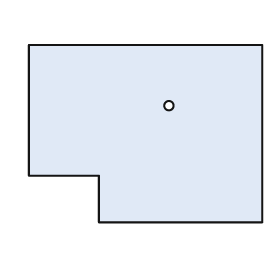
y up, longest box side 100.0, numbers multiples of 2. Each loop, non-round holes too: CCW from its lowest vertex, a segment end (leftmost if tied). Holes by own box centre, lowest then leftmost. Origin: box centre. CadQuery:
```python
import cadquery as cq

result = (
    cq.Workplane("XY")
    .moveTo(-20.0, -38.0)
    .lineTo(50.0, -38.0)
    .lineTo(50.0, 38.0)
    .lineTo(-50.0, 38.0)
    .lineTo(-50.0, -18.0)
    .lineTo(-20.0, -18.0)
    .close()
    .moveTo(10.0, 12.0)
    .circle(2.0)
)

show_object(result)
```